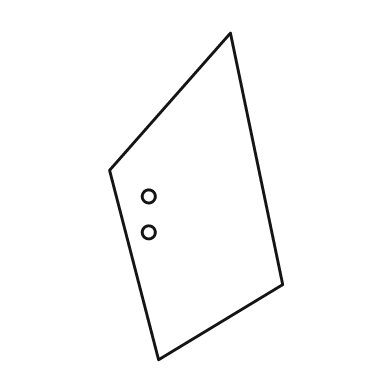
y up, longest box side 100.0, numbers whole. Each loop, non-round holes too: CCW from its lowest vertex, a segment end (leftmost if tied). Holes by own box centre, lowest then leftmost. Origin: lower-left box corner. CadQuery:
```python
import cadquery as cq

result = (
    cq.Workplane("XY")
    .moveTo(15.0, 0.0)
    .lineTo(53.0, 23.0)
    .lineTo(37.0, 100.0)
    .lineTo(0.0, 58.0)
    .close()
    .moveTo(12.0, 39.0)
    .circle(2.0)
    .moveTo(12.0, 50.0)
    .circle(2.0)
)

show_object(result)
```